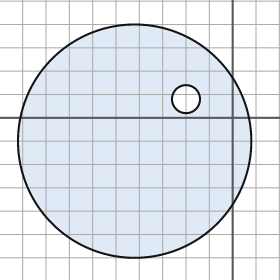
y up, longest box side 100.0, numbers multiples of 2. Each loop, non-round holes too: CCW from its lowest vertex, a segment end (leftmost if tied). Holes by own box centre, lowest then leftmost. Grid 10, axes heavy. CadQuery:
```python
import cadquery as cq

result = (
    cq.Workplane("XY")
    .moveTo(-42.0, -10.0)
    .circle(50.0)
    .moveTo(-20.0, 8.0)
    .circle(6.0)
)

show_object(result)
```